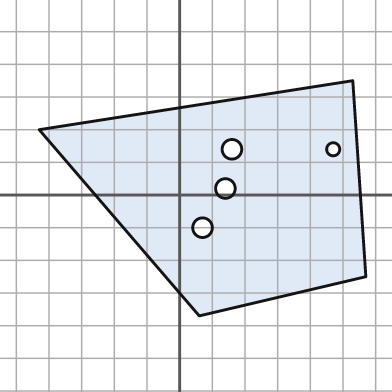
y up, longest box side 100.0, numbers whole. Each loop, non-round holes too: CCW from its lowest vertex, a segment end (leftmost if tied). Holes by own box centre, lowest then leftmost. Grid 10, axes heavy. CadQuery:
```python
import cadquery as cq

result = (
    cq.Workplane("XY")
    .moveTo(6.0, -37.0)
    .lineTo(57.0, -25.0)
    .lineTo(53.0, 35.0)
    .lineTo(-43.0, 20.0)
    .close()
    .moveTo(7.0, -10.0)
    .circle(3.0)
    .moveTo(14.0, 2.0)
    .circle(3.0)
    .moveTo(16.0, 14.0)
    .circle(3.0)
    .moveTo(47.0, 14.0)
    .circle(2.0)
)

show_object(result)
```